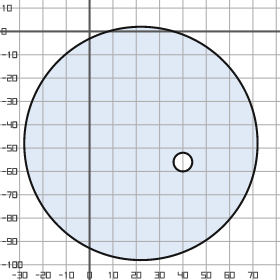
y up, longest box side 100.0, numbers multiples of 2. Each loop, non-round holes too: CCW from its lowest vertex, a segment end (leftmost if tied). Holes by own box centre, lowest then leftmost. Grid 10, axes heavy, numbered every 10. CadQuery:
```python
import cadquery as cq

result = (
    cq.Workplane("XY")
    .moveTo(22.0, -48.0)
    .circle(50.0)
    .moveTo(40.0, -56.0)
    .circle(4.0)
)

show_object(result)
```